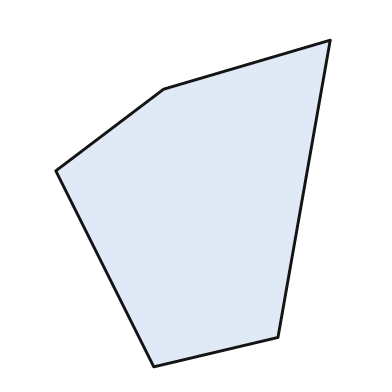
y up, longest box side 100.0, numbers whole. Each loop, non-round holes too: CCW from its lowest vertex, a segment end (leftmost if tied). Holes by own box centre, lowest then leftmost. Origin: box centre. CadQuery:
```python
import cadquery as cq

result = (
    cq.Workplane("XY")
    .moveTo(-12.0, -50.0)
    .lineTo(26.0, -41.0)
    .lineTo(42.0, 50.0)
    .lineTo(-9.0, 35.0)
    .lineTo(-42.0, 10.0)
    .close()
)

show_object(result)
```